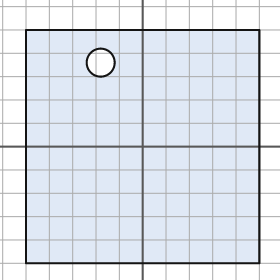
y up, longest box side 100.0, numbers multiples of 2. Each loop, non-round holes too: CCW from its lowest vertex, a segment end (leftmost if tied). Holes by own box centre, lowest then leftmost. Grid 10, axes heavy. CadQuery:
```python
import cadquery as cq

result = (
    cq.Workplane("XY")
    .moveTo(-50.0, -50.0)
    .lineTo(50.0, -50.0)
    .lineTo(50.0, 50.0)
    .lineTo(-50.0, 50.0)
    .close()
    .moveTo(-18.0, 36.0)
    .circle(6.0)
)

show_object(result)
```